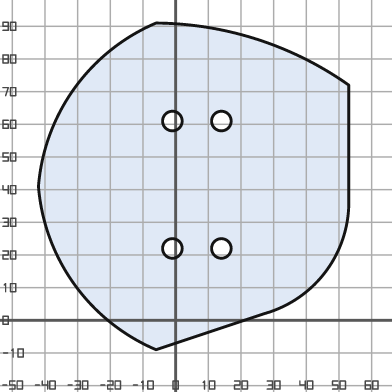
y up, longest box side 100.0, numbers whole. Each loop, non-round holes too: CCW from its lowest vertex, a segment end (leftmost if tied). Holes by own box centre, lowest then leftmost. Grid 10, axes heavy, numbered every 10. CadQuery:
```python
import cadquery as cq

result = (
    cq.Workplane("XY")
    .moveTo(-6.0, -9.0)
    .lineTo(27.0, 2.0)
    .threePointArc((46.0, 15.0), (53.0, 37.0))
    .lineTo(53.0, 72.0)
    .threePointArc((25.0, 86.0), (-6.0, 91.0))
    .threePointArc((-31.0, 71.0), (-42.0, 41.0))
    .threePointArc((-31.0, 11.0), (-6.0, -9.0))
    .close()
    .moveTo(-1.0, 22.0)
    .circle(3.0)
    .moveTo(14.0, 22.0)
    .circle(3.0)
    .moveTo(-1.0, 61.0)
    .circle(3.0)
    .moveTo(14.0, 61.0)
    .circle(3.0)
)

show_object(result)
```